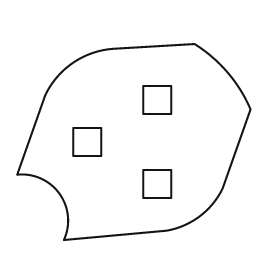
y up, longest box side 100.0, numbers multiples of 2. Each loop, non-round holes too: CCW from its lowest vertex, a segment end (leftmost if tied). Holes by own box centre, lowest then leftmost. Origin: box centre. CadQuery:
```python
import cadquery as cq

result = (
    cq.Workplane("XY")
    .moveTo(-30.0, -42.0)
    .lineTo(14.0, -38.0)
    .threePointArc((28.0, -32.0), (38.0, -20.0))
    .lineTo(50.0, 14.0)
    .threePointArc((40.0, 30.0), (26.0, 42.0))
    .lineTo(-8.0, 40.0)
    .threePointArc((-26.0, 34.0), (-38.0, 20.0))
    .lineTo(-50.0, -14.0)
    .threePointArc((-32.0, -22.0), (-30.0, -42.0))
    .close()
    .moveTo(4.0, -24.0)
    .lineTo(16.0, -24.0)
    .lineTo(16.0, -12.0)
    .lineTo(4.0, -12.0)
    .close()
    .moveTo(-26.0, -6.0)
    .lineTo(-14.0, -6.0)
    .lineTo(-14.0, 6.0)
    .lineTo(-26.0, 6.0)
    .close()
    .moveTo(4.0, 12.0)
    .lineTo(16.0, 12.0)
    .lineTo(16.0, 24.0)
    .lineTo(4.0, 24.0)
    .close()
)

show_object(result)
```